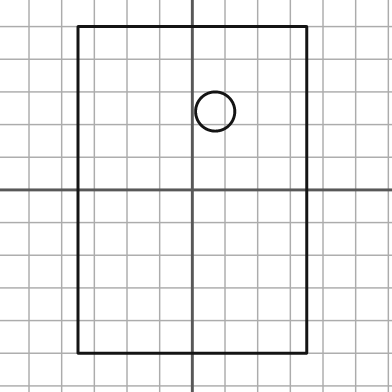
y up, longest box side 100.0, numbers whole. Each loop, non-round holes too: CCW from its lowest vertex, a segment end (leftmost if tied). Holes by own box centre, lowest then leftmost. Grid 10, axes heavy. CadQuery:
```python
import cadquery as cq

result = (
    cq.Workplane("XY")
    .moveTo(-35.0, -50.0)
    .lineTo(35.0, -50.0)
    .lineTo(35.0, 50.0)
    .lineTo(-35.0, 50.0)
    .close()
    .moveTo(7.0, 24.0)
    .circle(6.0)
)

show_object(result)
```